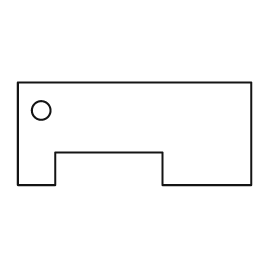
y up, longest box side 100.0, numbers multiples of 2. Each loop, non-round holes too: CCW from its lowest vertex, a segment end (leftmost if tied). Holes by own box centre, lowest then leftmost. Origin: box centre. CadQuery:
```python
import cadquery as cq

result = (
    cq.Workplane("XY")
    .moveTo(-50.0, -22.0)
    .lineTo(-34.0, -22.0)
    .lineTo(-34.0, -8.0)
    .lineTo(12.0, -8.0)
    .lineTo(12.0, -22.0)
    .lineTo(50.0, -22.0)
    .lineTo(50.0, 22.0)
    .lineTo(-50.0, 22.0)
    .close()
    .moveTo(-40.0, 10.0)
    .circle(4.0)
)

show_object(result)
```